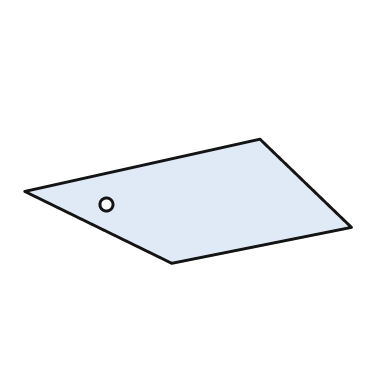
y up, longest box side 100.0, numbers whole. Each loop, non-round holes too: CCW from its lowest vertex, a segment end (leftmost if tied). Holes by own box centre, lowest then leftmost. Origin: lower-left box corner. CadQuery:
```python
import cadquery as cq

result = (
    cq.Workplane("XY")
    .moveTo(45.0, 0.0)
    .lineTo(100.0, 11.0)
    .lineTo(72.0, 38.0)
    .lineTo(0.0, 22.0)
    .close()
    .moveTo(25.0, 18.0)
    .circle(2.0)
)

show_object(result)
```